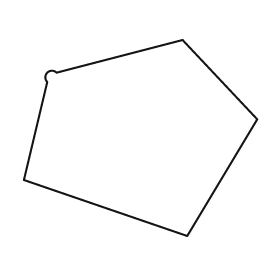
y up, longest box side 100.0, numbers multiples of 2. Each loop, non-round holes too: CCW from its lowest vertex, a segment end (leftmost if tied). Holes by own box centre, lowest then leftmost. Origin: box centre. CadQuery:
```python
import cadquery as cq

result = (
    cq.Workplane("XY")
    .moveTo(20.0, -42.0)
    .lineTo(50.0, 8.0)
    .lineTo(18.0, 42.0)
    .lineTo(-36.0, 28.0)
    .threePointArc((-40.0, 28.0), (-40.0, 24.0))
    .lineTo(-50.0, -18.0)
    .close()
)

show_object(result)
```